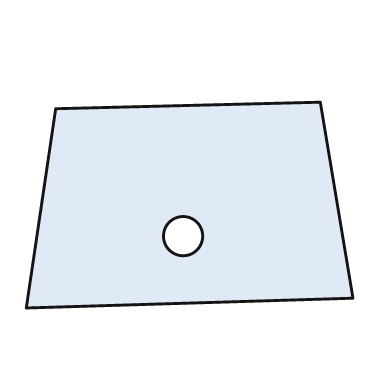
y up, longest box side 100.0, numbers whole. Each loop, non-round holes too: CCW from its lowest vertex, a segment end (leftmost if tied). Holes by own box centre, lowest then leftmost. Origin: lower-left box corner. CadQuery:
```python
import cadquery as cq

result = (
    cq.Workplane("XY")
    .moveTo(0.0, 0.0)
    .lineTo(100.0, 3.0)
    .lineTo(90.0, 63.0)
    .lineTo(9.0, 61.0)
    .close()
    .moveTo(48.0, 22.0)
    .circle(6.0)
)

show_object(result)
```